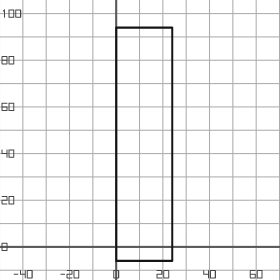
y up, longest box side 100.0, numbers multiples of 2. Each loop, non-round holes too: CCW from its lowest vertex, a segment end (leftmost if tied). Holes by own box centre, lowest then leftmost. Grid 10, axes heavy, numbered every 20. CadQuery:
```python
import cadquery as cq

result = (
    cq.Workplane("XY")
    .moveTo(0.0, -6.0)
    .lineTo(24.0, -6.0)
    .lineTo(24.0, 94.0)
    .lineTo(0.0, 94.0)
    .close()
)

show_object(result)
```